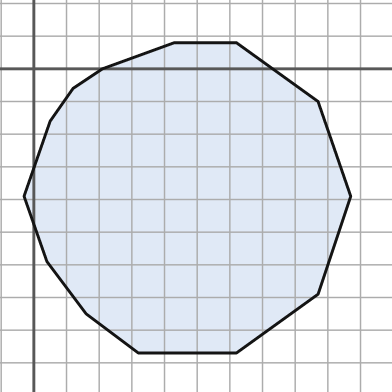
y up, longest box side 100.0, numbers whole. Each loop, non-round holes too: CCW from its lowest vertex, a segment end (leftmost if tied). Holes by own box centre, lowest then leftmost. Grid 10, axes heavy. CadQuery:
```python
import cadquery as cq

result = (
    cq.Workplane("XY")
    .moveTo(32.0, -87.0)
    .lineTo(62.0, -87.0)
    .lineTo(87.0, -69.0)
    .lineTo(97.0, -39.0)
    .lineTo(87.0, -10.0)
    .lineTo(62.0, 8.0)
    .lineTo(43.0, 8.0)
    .lineTo(21.0, 0.0)
    .lineTo(12.0, -6.0)
    .lineTo(5.0, -16.0)
    .lineTo(-3.0, -39.0)
    .lineTo(4.0, -59.0)
    .lineTo(16.0, -75.0)
    .close()
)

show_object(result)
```